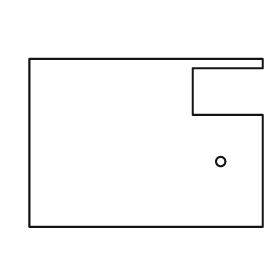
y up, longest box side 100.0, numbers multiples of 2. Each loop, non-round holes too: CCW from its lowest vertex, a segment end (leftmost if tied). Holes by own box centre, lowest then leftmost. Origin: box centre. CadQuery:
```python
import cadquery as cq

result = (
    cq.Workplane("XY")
    .moveTo(-50.0, -36.0)
    .lineTo(50.0, -36.0)
    .lineTo(50.0, 12.0)
    .lineTo(20.0, 12.0)
    .lineTo(20.0, 32.0)
    .lineTo(50.0, 32.0)
    .lineTo(50.0, 36.0)
    .lineTo(-50.0, 36.0)
    .close()
    .moveTo(32.0, -8.0)
    .circle(2.0)
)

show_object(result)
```